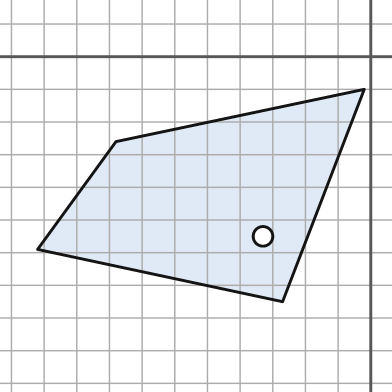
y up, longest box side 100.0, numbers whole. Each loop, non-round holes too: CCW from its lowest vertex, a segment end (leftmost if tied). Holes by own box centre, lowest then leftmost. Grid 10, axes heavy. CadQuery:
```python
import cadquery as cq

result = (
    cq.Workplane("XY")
    .moveTo(-27.0, -75.0)
    .lineTo(-2.0, -10.0)
    .lineTo(-78.0, -26.0)
    .lineTo(-102.0, -59.0)
    .close()
    .moveTo(-33.0, -55.0)
    .circle(3.0)
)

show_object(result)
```